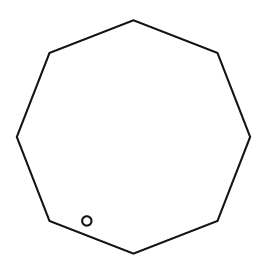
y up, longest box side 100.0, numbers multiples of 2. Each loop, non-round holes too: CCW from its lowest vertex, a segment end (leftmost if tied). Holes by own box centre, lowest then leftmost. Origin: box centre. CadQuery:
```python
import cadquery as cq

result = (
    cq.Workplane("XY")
    .moveTo(0.0, -50.0)
    .lineTo(36.0, -36.0)
    .lineTo(50.0, 0.0)
    .lineTo(36.0, 36.0)
    .lineTo(0.0, 50.0)
    .lineTo(-36.0, 36.0)
    .lineTo(-50.0, 0.0)
    .lineTo(-36.0, -36.0)
    .close()
    .moveTo(-20.0, -36.0)
    .circle(2.0)
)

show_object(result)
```